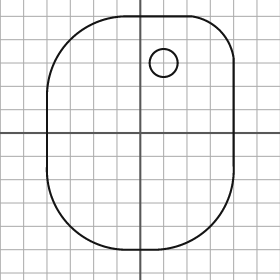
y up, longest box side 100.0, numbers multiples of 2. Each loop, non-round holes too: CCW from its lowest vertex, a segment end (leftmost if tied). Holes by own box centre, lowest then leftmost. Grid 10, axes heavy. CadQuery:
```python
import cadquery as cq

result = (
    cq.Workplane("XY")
    .moveTo(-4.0, -50.0)
    .lineTo(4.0, -50.0)
    .threePointArc((30.0, -40.0), (40.0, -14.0))
    .lineTo(40.0, 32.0)
    .threePointArc((34.0, 44.0), (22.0, 50.0))
    .lineTo(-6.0, 50.0)
    .threePointArc((-30.0, 40.0), (-40.0, 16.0))
    .lineTo(-40.0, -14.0)
    .threePointArc((-30.0, -40.0), (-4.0, -50.0))
    .close()
    .moveTo(10.0, 30.0)
    .circle(6.0)
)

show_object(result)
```